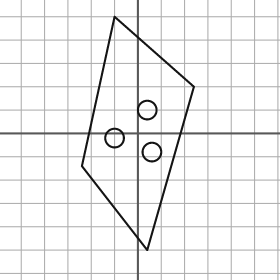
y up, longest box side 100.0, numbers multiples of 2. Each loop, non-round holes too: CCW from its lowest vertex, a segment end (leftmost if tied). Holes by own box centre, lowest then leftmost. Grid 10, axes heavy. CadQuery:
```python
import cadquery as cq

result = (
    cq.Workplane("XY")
    .moveTo(4.0, -50.0)
    .lineTo(24.0, 20.0)
    .lineTo(-10.0, 50.0)
    .lineTo(-24.0, -14.0)
    .close()
    .moveTo(6.0, -8.0)
    .circle(4.0)
    .moveTo(-10.0, -2.0)
    .circle(4.0)
    .moveTo(4.0, 10.0)
    .circle(4.0)
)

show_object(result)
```